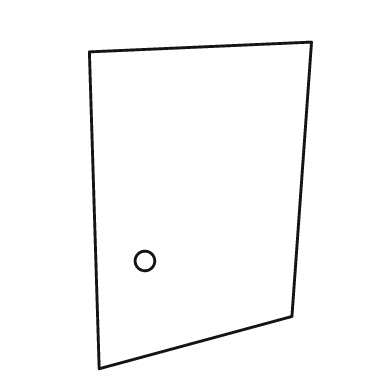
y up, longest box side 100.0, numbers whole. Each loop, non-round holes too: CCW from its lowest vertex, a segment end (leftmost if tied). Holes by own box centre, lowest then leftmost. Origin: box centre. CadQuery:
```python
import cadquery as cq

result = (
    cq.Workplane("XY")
    .moveTo(-31.0, -50.0)
    .lineTo(28.0, -34.0)
    .lineTo(34.0, 50.0)
    .lineTo(-34.0, 47.0)
    .close()
    .moveTo(-17.0, -17.0)
    .circle(3.0)
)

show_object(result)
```